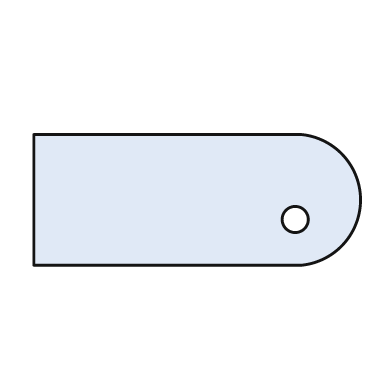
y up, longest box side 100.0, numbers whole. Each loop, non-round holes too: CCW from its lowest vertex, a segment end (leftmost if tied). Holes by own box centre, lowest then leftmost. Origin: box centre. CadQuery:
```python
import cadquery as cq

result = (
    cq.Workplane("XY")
    .moveTo(-50.0, -20.0)
    .lineTo(32.0, -20.0)
    .threePointArc((50.0, 0.0), (32.0, 20.0))
    .lineTo(-50.0, 20.0)
    .close()
    .moveTo(30.0, -6.0)
    .circle(4.0)
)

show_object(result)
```